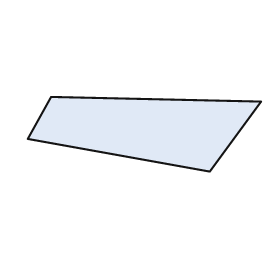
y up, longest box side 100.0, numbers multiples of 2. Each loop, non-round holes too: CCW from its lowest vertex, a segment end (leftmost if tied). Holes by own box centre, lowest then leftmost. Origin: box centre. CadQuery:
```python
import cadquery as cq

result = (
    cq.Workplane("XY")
    .moveTo(28.0, -16.0)
    .lineTo(50.0, 14.0)
    .lineTo(-40.0, 16.0)
    .lineTo(-50.0, -2.0)
    .close()
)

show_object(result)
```